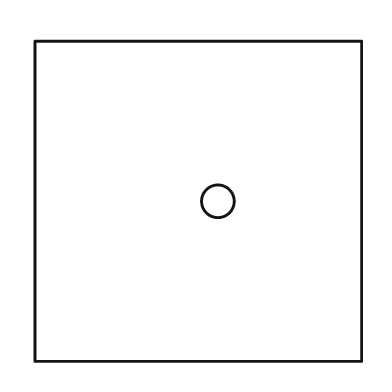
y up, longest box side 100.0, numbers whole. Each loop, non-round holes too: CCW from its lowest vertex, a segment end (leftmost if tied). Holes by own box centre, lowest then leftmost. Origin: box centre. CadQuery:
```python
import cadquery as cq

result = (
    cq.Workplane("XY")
    .moveTo(-50.0, -49.0)
    .lineTo(50.0, -49.0)
    .lineTo(50.0, 49.0)
    .lineTo(-50.0, 49.0)
    .close()
    .moveTo(6.0, 0.0)
    .circle(5.0)
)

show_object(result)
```